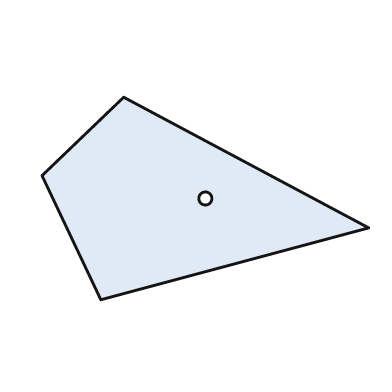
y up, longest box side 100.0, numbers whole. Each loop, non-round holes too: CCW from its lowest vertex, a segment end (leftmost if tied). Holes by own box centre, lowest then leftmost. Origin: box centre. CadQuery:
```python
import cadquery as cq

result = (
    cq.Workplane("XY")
    .moveTo(-32.0, -31.0)
    .lineTo(50.0, -9.0)
    .lineTo(-25.0, 31.0)
    .lineTo(-50.0, 7.0)
    .close()
    .moveTo(0.0, 0.0)
    .circle(2.0)
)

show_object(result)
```